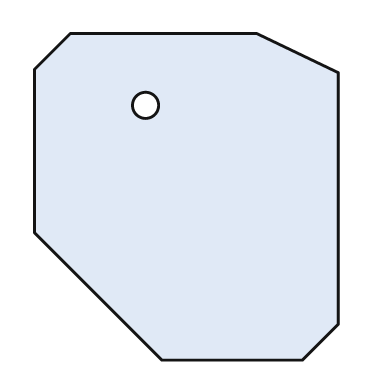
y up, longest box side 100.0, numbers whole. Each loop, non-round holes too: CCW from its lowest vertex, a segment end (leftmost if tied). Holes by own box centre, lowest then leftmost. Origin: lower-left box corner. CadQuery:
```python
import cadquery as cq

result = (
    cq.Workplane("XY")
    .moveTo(39.0, 0.0)
    .lineTo(82.0, 0.0)
    .lineTo(93.0, 11.0)
    .lineTo(93.0, 88.0)
    .lineTo(68.0, 100.0)
    .lineTo(11.0, 100.0)
    .lineTo(0.0, 89.0)
    .lineTo(0.0, 39.0)
    .close()
    .moveTo(34.0, 78.0)
    .circle(4.0)
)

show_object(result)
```